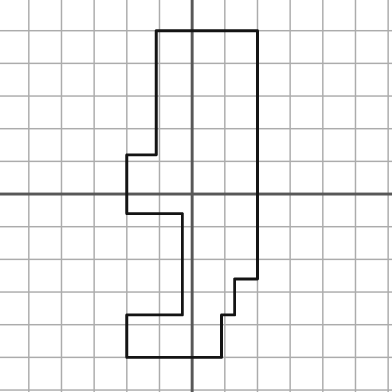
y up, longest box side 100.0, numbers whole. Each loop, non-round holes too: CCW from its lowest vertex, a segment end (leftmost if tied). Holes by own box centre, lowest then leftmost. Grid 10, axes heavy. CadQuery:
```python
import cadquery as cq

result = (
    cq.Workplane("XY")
    .moveTo(-20.0, -50.0)
    .lineTo(9.0, -50.0)
    .lineTo(9.0, -37.0)
    .lineTo(13.0, -37.0)
    .lineTo(13.0, -26.0)
    .lineTo(20.0, -26.0)
    .lineTo(20.0, 50.0)
    .lineTo(-11.0, 50.0)
    .lineTo(-11.0, 12.0)
    .lineTo(-20.0, 12.0)
    .lineTo(-20.0, -6.0)
    .lineTo(-3.0, -6.0)
    .lineTo(-3.0, -37.0)
    .lineTo(-20.0, -37.0)
    .close()
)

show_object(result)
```